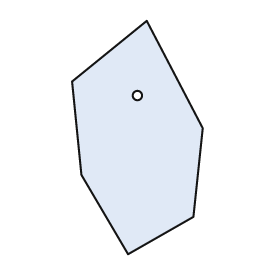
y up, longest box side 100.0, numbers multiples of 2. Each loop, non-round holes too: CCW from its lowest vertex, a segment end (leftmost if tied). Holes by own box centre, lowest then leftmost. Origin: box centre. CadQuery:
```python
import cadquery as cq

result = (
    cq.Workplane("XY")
    .moveTo(-4.0, -50.0)
    .lineTo(24.0, -34.0)
    .lineTo(28.0, 4.0)
    .lineTo(4.0, 50.0)
    .lineTo(-28.0, 24.0)
    .lineTo(-24.0, -16.0)
    .close()
    .moveTo(0.0, 18.0)
    .circle(2.0)
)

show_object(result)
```